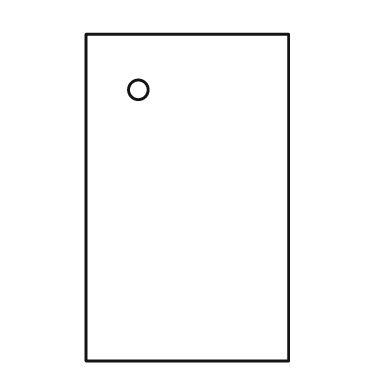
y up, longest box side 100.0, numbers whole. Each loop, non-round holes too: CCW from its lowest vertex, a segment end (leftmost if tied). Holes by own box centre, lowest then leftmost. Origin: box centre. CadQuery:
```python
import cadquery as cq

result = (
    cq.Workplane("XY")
    .moveTo(-31.0, -50.0)
    .lineTo(31.0, -50.0)
    .lineTo(31.0, 50.0)
    .lineTo(-31.0, 50.0)
    .close()
    .moveTo(-15.0, 33.0)
    .circle(3.0)
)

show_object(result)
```